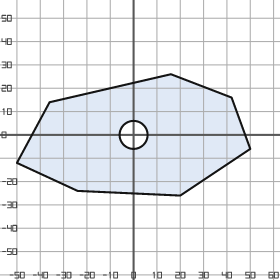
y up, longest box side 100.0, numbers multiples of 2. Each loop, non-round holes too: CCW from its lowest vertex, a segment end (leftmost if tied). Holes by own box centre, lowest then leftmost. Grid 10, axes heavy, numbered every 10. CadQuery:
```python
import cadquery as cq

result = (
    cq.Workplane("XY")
    .moveTo(20.0, -26.0)
    .lineTo(50.0, -6.0)
    .lineTo(42.0, 16.0)
    .lineTo(16.0, 26.0)
    .lineTo(-36.0, 14.0)
    .lineTo(-50.0, -12.0)
    .lineTo(-24.0, -24.0)
    .close()
    .moveTo(0.0, 0.0)
    .circle(6.0)
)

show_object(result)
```